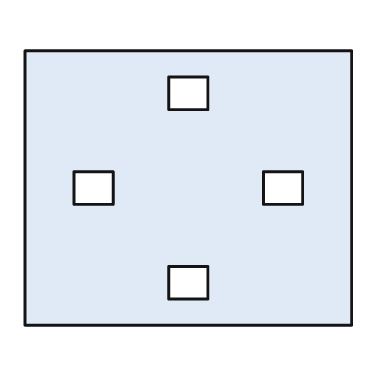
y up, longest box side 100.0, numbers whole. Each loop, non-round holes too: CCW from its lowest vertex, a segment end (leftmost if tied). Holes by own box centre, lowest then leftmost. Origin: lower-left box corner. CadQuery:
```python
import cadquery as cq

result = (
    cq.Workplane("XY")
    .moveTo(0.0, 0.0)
    .lineTo(100.0, 0.0)
    .lineTo(100.0, 84.0)
    .lineTo(0.0, 84.0)
    .close()
    .moveTo(44.0, 8.0)
    .lineTo(56.0, 8.0)
    .lineTo(56.0, 18.0)
    .lineTo(44.0, 18.0)
    .close()
    .moveTo(15.0, 37.0)
    .lineTo(27.0, 37.0)
    .lineTo(27.0, 47.0)
    .lineTo(15.0, 47.0)
    .close()
    .moveTo(73.0, 37.0)
    .lineTo(85.0, 37.0)
    .lineTo(85.0, 47.0)
    .lineTo(73.0, 47.0)
    .close()
    .moveTo(44.0, 66.0)
    .lineTo(56.0, 66.0)
    .lineTo(56.0, 76.0)
    .lineTo(44.0, 76.0)
    .close()
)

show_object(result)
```